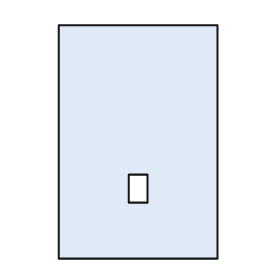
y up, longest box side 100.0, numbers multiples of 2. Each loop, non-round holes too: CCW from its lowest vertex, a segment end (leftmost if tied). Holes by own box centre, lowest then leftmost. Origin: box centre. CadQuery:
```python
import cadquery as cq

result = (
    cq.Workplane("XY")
    .moveTo(-34.0, -50.0)
    .lineTo(34.0, -50.0)
    .lineTo(34.0, 50.0)
    .lineTo(-34.0, 50.0)
    .close()
    .moveTo(-4.0, -26.0)
    .lineTo(4.0, -26.0)
    .lineTo(4.0, -14.0)
    .lineTo(-4.0, -14.0)
    .close()
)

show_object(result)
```